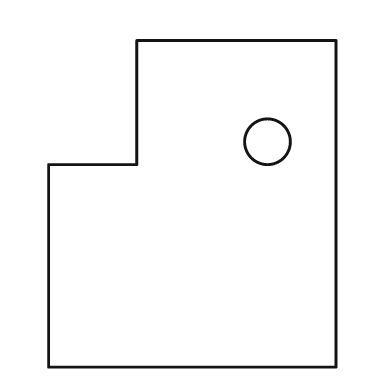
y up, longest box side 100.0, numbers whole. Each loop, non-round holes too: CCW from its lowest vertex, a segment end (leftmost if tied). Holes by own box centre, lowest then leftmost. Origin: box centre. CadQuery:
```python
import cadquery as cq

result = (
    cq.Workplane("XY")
    .moveTo(-44.0, -50.0)
    .lineTo(44.0, -50.0)
    .lineTo(44.0, 50.0)
    .lineTo(-17.0, 50.0)
    .lineTo(-17.0, 12.0)
    .lineTo(-44.0, 12.0)
    .close()
    .moveTo(23.0, 19.0)
    .circle(7.0)
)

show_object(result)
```